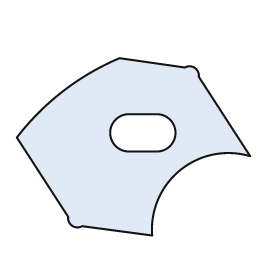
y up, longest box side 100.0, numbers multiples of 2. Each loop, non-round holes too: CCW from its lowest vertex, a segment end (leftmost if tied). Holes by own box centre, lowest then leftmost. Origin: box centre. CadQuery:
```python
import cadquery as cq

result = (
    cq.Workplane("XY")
    .moveTo(8.0, -38.0)
    .threePointArc((20.0, -10.0), (50.0, -4.0))
    .lineTo(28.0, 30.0)
    .threePointArc((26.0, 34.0), (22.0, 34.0))
    .lineTo(-6.0, 38.0)
    .threePointArc((-30.0, 24.0), (-50.0, 4.0))
    .lineTo(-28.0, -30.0)
    .threePointArc((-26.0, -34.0), (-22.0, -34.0))
    .close()
    .moveTo(-2.0, -2.0)
    .lineTo(10.0, -2.0)
    .threePointArc((18.0, 6.0), (10.0, 14.0))
    .lineTo(-2.0, 14.0)
    .threePointArc((-10.0, 6.0), (-2.0, -2.0))
    .close()
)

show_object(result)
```